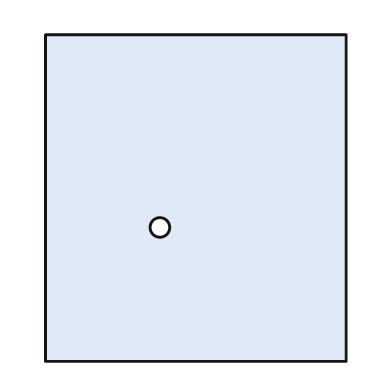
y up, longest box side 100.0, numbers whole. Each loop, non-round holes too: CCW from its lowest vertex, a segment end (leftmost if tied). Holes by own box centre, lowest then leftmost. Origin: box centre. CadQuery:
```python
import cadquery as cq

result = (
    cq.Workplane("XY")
    .moveTo(-46.0, -50.0)
    .lineTo(46.0, -50.0)
    .lineTo(46.0, 50.0)
    .lineTo(-46.0, 50.0)
    .close()
    .moveTo(-11.0, -9.0)
    .circle(3.0)
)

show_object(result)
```